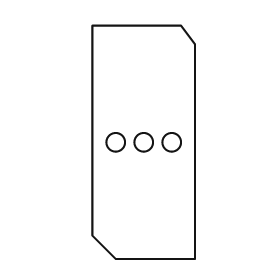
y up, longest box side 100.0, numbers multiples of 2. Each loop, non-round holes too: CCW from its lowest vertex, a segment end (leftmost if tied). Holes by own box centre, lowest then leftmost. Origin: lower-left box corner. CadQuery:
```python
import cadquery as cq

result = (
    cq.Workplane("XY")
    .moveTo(10.0, 0.0)
    .lineTo(44.0, 0.0)
    .lineTo(44.0, 92.0)
    .lineTo(38.0, 100.0)
    .lineTo(0.0, 100.0)
    .lineTo(0.0, 10.0)
    .close()
    .moveTo(10.0, 50.0)
    .circle(4.0)
    .moveTo(22.0, 50.0)
    .circle(4.0)
    .moveTo(34.0, 50.0)
    .circle(4.0)
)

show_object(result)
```